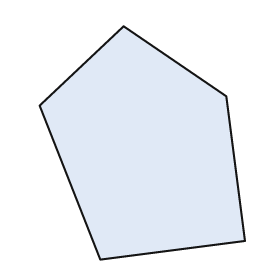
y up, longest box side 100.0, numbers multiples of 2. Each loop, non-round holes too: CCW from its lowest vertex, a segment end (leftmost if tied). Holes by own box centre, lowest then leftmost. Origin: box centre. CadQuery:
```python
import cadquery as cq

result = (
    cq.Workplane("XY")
    .moveTo(-18.0, -50.0)
    .lineTo(44.0, -42.0)
    .lineTo(36.0, 20.0)
    .lineTo(-8.0, 50.0)
    .lineTo(-44.0, 16.0)
    .close()
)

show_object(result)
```